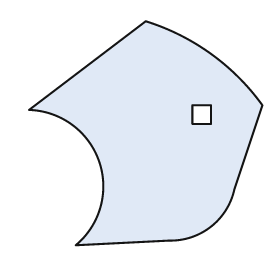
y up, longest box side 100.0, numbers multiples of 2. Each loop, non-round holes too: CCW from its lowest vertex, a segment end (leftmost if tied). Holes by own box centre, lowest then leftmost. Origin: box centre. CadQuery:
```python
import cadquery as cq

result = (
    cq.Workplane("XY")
    .moveTo(-30.0, -48.0)
    .lineTo(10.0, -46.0)
    .threePointArc((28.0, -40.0), (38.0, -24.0))
    .lineTo(50.0, 12.0)
    .threePointArc((28.0, 34.0), (0.0, 48.0))
    .lineTo(-50.0, 10.0)
    .threePointArc((-20.0, -12.0), (-30.0, -48.0))
    .close()
    .moveTo(20.0, 4.0)
    .lineTo(28.0, 4.0)
    .lineTo(28.0, 12.0)
    .lineTo(20.0, 12.0)
    .close()
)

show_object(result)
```